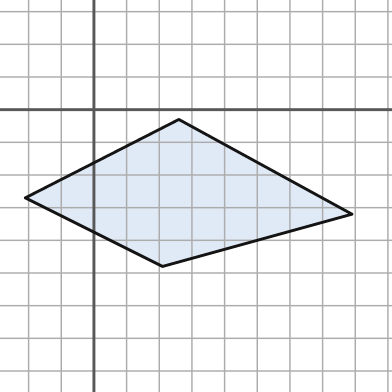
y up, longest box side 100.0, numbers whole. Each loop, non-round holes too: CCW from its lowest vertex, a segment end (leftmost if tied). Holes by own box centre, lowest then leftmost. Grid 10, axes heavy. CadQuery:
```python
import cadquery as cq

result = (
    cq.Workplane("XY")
    .moveTo(21.0, -48.0)
    .lineTo(79.0, -32.0)
    .lineTo(26.0, -3.0)
    .lineTo(-21.0, -27.0)
    .close()
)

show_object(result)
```